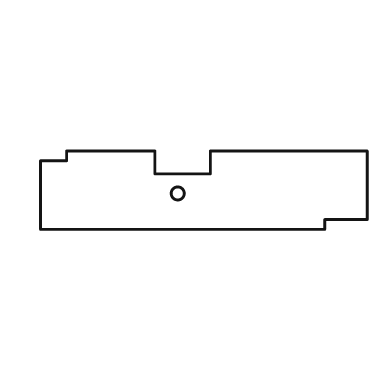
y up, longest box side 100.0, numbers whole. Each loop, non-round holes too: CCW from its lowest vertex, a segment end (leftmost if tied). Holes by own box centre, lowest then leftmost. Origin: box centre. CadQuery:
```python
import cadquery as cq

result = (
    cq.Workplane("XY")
    .moveTo(-50.0, -12.0)
    .lineTo(37.0, -12.0)
    .lineTo(37.0, -9.0)
    .lineTo(50.0, -9.0)
    .lineTo(50.0, 12.0)
    .lineTo(2.0, 12.0)
    .lineTo(2.0, 5.0)
    .lineTo(-15.0, 5.0)
    .lineTo(-15.0, 12.0)
    .lineTo(-42.0, 12.0)
    .lineTo(-42.0, 9.0)
    .lineTo(-50.0, 9.0)
    .close()
    .moveTo(-8.0, -1.0)
    .circle(2.0)
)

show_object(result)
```